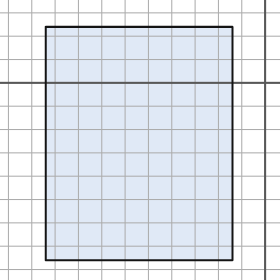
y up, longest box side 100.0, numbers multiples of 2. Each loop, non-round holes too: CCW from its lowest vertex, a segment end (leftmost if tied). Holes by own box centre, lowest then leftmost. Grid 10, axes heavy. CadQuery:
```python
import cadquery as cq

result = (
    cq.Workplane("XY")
    .moveTo(-94.0, -76.0)
    .lineTo(-14.0, -76.0)
    .lineTo(-14.0, 24.0)
    .lineTo(-94.0, 24.0)
    .close()
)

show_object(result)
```